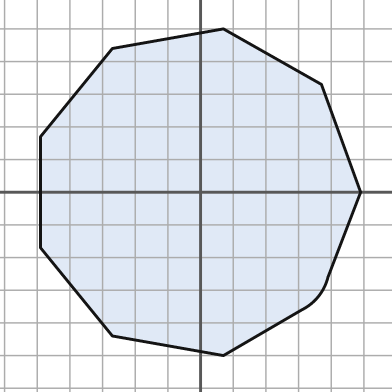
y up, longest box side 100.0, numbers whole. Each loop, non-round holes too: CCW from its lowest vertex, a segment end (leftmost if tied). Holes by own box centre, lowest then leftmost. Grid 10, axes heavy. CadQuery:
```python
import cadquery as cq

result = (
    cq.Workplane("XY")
    .moveTo(7.0, -50.0)
    .lineTo(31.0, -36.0)
    .threePointArc((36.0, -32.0), (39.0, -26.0))
    .lineTo(49.0, 0.0)
    .lineTo(37.0, 33.0)
    .lineTo(7.0, 50.0)
    .lineTo(-27.0, 44.0)
    .lineTo(-49.0, 17.0)
    .lineTo(-49.0, -17.0)
    .lineTo(-27.0, -44.0)
    .close()
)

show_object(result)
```